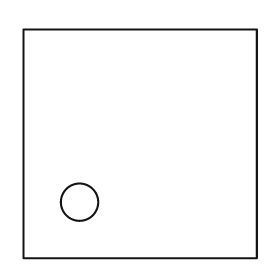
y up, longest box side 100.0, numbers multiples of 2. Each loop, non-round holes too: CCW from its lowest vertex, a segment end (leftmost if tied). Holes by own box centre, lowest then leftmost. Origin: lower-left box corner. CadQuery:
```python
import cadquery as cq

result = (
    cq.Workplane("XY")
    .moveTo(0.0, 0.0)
    .lineTo(100.0, 0.0)
    .lineTo(100.0, 98.0)
    .lineTo(0.0, 98.0)
    .close()
    .moveTo(24.0, 24.0)
    .circle(8.0)
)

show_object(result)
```